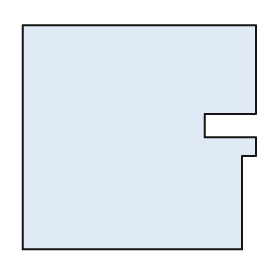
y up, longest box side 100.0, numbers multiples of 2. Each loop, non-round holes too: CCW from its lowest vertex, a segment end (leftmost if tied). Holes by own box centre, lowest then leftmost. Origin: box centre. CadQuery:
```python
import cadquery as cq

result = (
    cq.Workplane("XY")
    .moveTo(-50.0, -48.0)
    .lineTo(44.0, -48.0)
    .lineTo(44.0, -8.0)
    .lineTo(50.0, -8.0)
    .lineTo(50.0, 0.0)
    .lineTo(28.0, 0.0)
    .lineTo(28.0, 10.0)
    .lineTo(50.0, 10.0)
    .lineTo(50.0, 48.0)
    .lineTo(-50.0, 48.0)
    .close()
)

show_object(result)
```